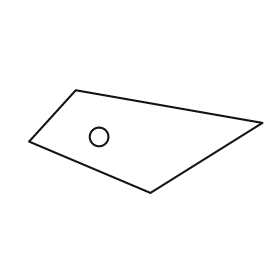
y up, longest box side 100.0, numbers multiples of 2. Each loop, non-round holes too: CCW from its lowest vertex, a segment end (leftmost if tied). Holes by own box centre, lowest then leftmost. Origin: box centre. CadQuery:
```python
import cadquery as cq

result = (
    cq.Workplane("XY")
    .moveTo(2.0, -22.0)
    .lineTo(50.0, 8.0)
    .lineTo(-30.0, 22.0)
    .lineTo(-50.0, 0.0)
    .close()
    .moveTo(-20.0, 2.0)
    .circle(4.0)
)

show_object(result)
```